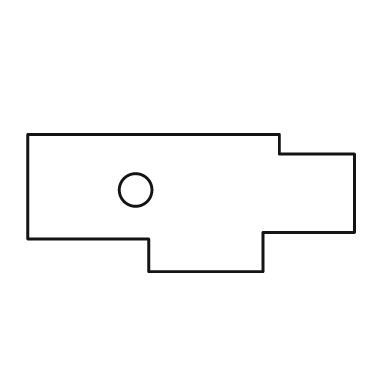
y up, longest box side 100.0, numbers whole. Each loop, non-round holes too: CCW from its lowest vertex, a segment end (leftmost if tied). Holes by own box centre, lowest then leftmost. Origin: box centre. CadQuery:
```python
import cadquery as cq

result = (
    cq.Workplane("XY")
    .moveTo(-13.0, -21.0)
    .lineTo(22.0, -21.0)
    .lineTo(22.0, -9.0)
    .lineTo(50.0, -9.0)
    .lineTo(50.0, 15.0)
    .lineTo(27.0, 15.0)
    .lineTo(27.0, 21.0)
    .lineTo(-50.0, 21.0)
    .lineTo(-50.0, -11.0)
    .lineTo(-13.0, -11.0)
    .close()
    .moveTo(-17.0, 4.0)
    .circle(5.0)
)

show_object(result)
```